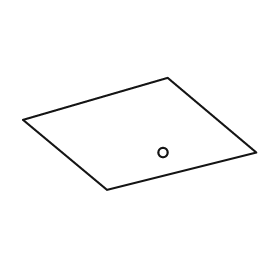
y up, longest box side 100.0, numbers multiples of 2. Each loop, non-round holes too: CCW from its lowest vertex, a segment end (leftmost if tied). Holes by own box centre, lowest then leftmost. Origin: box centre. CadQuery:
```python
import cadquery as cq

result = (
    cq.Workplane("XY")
    .moveTo(-14.0, -24.0)
    .lineTo(50.0, -8.0)
    .lineTo(12.0, 24.0)
    .lineTo(-50.0, 6.0)
    .close()
    .moveTo(10.0, -8.0)
    .circle(2.0)
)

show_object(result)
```